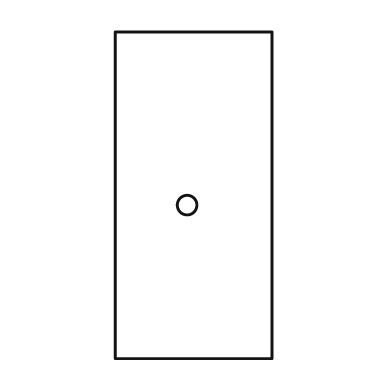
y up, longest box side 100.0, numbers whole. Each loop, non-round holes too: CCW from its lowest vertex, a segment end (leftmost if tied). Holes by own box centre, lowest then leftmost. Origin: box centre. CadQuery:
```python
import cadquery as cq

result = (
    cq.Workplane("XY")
    .moveTo(-24.0, -50.0)
    .lineTo(24.0, -50.0)
    .lineTo(24.0, 50.0)
    .lineTo(-24.0, 50.0)
    .close()
    .moveTo(-2.0, -3.0)
    .circle(3.0)
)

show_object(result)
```